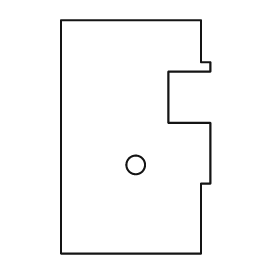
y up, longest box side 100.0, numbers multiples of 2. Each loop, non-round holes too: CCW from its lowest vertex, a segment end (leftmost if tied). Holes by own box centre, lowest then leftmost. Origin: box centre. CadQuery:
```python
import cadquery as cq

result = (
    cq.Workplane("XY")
    .moveTo(-32.0, -50.0)
    .lineTo(28.0, -50.0)
    .lineTo(28.0, -20.0)
    .lineTo(32.0, -20.0)
    .lineTo(32.0, 6.0)
    .lineTo(14.0, 6.0)
    .lineTo(14.0, 28.0)
    .lineTo(32.0, 28.0)
    .lineTo(32.0, 32.0)
    .lineTo(28.0, 32.0)
    .lineTo(28.0, 50.0)
    .lineTo(-32.0, 50.0)
    .close()
    .moveTo(0.0, -12.0)
    .circle(4.0)
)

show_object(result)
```